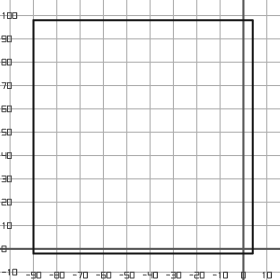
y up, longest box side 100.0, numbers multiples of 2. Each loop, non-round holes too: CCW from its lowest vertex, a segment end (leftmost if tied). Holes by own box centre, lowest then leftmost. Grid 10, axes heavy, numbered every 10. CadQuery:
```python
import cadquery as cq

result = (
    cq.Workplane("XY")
    .moveTo(-90.0, -2.0)
    .lineTo(4.0, -2.0)
    .lineTo(4.0, 98.0)
    .lineTo(-90.0, 98.0)
    .close()
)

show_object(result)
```